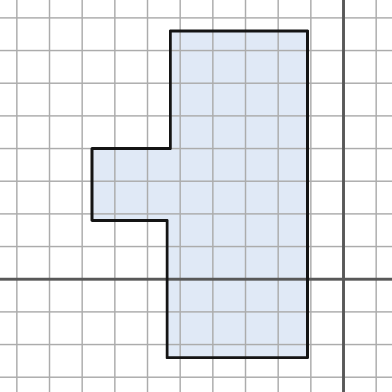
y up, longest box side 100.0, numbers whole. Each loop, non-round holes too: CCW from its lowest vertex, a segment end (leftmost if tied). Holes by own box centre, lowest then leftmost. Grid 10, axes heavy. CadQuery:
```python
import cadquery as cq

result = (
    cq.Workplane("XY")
    .moveTo(-54.0, -24.0)
    .lineTo(-11.0, -24.0)
    .lineTo(-11.0, 76.0)
    .lineTo(-53.0, 76.0)
    .lineTo(-53.0, 40.0)
    .lineTo(-77.0, 40.0)
    .lineTo(-77.0, 18.0)
    .lineTo(-54.0, 18.0)
    .close()
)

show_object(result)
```